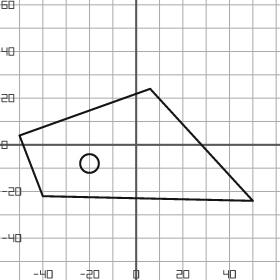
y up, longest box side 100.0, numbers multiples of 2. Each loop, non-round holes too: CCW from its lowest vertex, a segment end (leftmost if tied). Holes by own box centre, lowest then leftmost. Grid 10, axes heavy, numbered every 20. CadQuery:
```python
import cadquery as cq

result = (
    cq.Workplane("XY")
    .moveTo(50.0, -24.0)
    .lineTo(6.0, 24.0)
    .lineTo(-50.0, 4.0)
    .lineTo(-40.0, -22.0)
    .close()
    .moveTo(-20.0, -8.0)
    .circle(4.0)
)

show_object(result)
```